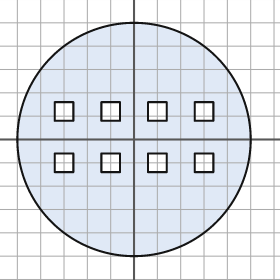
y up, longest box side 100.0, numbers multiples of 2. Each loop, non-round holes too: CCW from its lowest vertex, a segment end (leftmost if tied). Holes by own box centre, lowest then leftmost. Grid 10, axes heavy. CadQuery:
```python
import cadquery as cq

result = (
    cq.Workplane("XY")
    .moveTo(0.0, 0.0)
    .circle(50.0)
    .moveTo(-34.0, -14.0)
    .lineTo(-26.0, -14.0)
    .lineTo(-26.0, -6.0)
    .lineTo(-34.0, -6.0)
    .close()
    .moveTo(-14.0, -14.0)
    .lineTo(-6.0, -14.0)
    .lineTo(-6.0, -6.0)
    .lineTo(-14.0, -6.0)
    .close()
    .moveTo(6.0, -14.0)
    .lineTo(14.0, -14.0)
    .lineTo(14.0, -6.0)
    .lineTo(6.0, -6.0)
    .close()
    .moveTo(26.0, -14.0)
    .lineTo(34.0, -14.0)
    .lineTo(34.0, -6.0)
    .lineTo(26.0, -6.0)
    .close()
    .moveTo(-34.0, 8.0)
    .lineTo(-26.0, 8.0)
    .lineTo(-26.0, 16.0)
    .lineTo(-34.0, 16.0)
    .close()
    .moveTo(-14.0, 8.0)
    .lineTo(-6.0, 8.0)
    .lineTo(-6.0, 16.0)
    .lineTo(-14.0, 16.0)
    .close()
    .moveTo(6.0, 8.0)
    .lineTo(14.0, 8.0)
    .lineTo(14.0, 16.0)
    .lineTo(6.0, 16.0)
    .close()
    .moveTo(26.0, 8.0)
    .lineTo(34.0, 8.0)
    .lineTo(34.0, 16.0)
    .lineTo(26.0, 16.0)
    .close()
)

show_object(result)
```